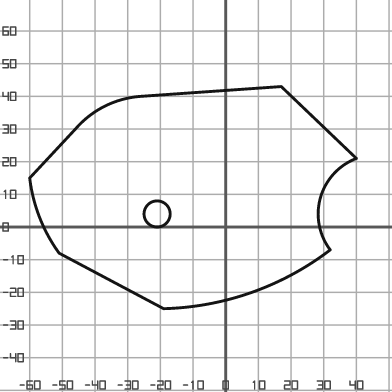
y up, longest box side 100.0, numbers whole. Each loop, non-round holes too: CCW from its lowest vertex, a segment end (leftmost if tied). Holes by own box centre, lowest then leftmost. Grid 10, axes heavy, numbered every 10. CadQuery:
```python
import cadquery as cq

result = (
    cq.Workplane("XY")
    .moveTo(-19.0, -25.0)
    .threePointArc((8.0, -20.0), (32.0, -7.0))
    .threePointArc((29.0, 9.0), (40.0, 21.0))
    .lineTo(17.0, 43.0)
    .lineTo(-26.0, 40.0)
    .threePointArc((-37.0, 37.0), (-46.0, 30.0))
    .lineTo(-60.0, 15.0)
    .threePointArc((-57.0, 3.0), (-51.0, -8.0))
    .close()
    .moveTo(-21.0, 4.0)
    .circle(4.0)
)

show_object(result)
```